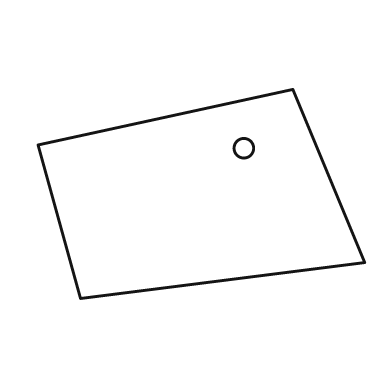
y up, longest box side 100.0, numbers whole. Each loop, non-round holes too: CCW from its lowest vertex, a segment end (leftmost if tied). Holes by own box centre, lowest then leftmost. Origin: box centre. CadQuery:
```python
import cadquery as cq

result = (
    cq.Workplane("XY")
    .moveTo(-37.0, -32.0)
    .lineTo(50.0, -21.0)
    .lineTo(28.0, 32.0)
    .lineTo(-50.0, 15.0)
    .close()
    .moveTo(13.0, 14.0)
    .circle(3.0)
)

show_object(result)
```